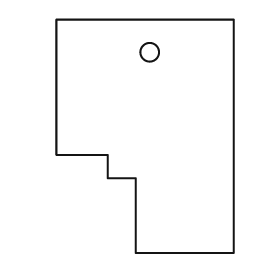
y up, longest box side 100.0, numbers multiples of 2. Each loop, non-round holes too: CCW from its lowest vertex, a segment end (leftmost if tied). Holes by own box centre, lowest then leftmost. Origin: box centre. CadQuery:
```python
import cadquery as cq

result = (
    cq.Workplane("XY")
    .moveTo(-4.0, -50.0)
    .lineTo(38.0, -50.0)
    .lineTo(38.0, 50.0)
    .lineTo(-38.0, 50.0)
    .lineTo(-38.0, -8.0)
    .lineTo(-16.0, -8.0)
    .lineTo(-16.0, -18.0)
    .lineTo(-4.0, -18.0)
    .close()
    .moveTo(2.0, 36.0)
    .circle(4.0)
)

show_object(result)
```